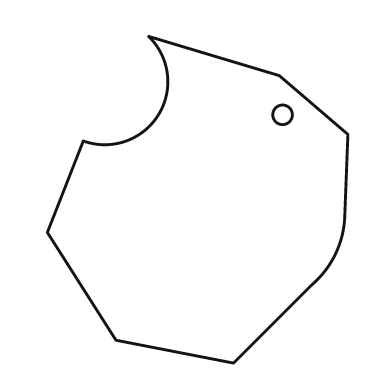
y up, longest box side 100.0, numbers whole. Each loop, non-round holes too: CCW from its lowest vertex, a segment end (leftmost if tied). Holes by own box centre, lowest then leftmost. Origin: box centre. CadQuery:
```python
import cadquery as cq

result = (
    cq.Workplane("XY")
    .moveTo(11.0, -50.0)
    .lineTo(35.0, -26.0)
    .threePointArc((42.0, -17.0), (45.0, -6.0))
    .lineTo(46.0, 20.0)
    .lineTo(25.0, 38.0)
    .lineTo(-15.0, 50.0)
    .threePointArc((-12.0, 26.0), (-35.0, 18.0))
    .lineTo(-46.0, -10.0)
    .lineTo(-25.0, -43.0)
    .close()
    .moveTo(26.0, 26.0)
    .circle(3.0)
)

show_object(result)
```